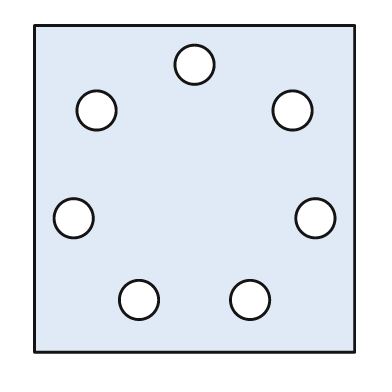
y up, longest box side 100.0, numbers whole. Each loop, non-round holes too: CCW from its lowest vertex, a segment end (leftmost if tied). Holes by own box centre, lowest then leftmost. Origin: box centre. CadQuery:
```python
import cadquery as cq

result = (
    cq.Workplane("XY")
    .moveTo(-49.0, -50.0)
    .lineTo(49.0, -50.0)
    .lineTo(49.0, 50.0)
    .lineTo(-49.0, 50.0)
    .close()
    .moveTo(-17.0, -34.0)
    .circle(6.0)
    .moveTo(17.0, -34.0)
    .circle(6.0)
    .moveTo(-37.0, -9.0)
    .circle(6.0)
    .moveTo(37.0, -9.0)
    .circle(6.0)
    .moveTo(-30.0, 24.0)
    .circle(6.0)
    .moveTo(30.0, 24.0)
    .circle(6.0)
    .moveTo(0.0, 38.0)
    .circle(6.0)
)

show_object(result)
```